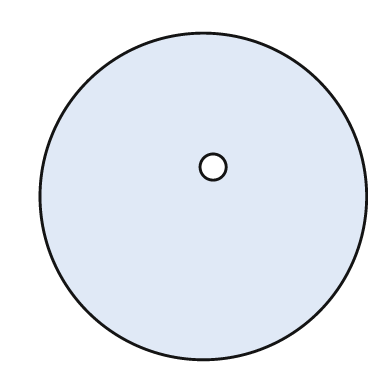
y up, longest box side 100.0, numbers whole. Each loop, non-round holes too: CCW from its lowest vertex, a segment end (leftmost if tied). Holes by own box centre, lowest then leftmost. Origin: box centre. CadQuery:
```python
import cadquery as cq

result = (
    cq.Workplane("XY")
    .moveTo(0.0, 0.0)
    .circle(50.0)
    .moveTo(3.0, 9.0)
    .circle(4.0)
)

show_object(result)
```